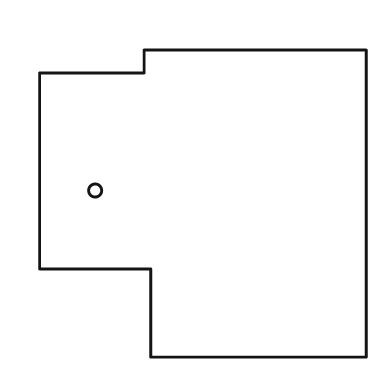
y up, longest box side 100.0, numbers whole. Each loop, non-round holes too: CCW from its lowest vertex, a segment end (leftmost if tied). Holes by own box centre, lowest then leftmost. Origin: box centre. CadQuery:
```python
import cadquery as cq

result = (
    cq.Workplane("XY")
    .moveTo(-16.0, -47.0)
    .lineTo(50.0, -47.0)
    .lineTo(50.0, 47.0)
    .lineTo(-18.0, 47.0)
    .lineTo(-18.0, 40.0)
    .lineTo(-50.0, 40.0)
    .lineTo(-50.0, -20.0)
    .lineTo(-16.0, -20.0)
    .close()
    .moveTo(-33.0, 4.0)
    .circle(2.0)
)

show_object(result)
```